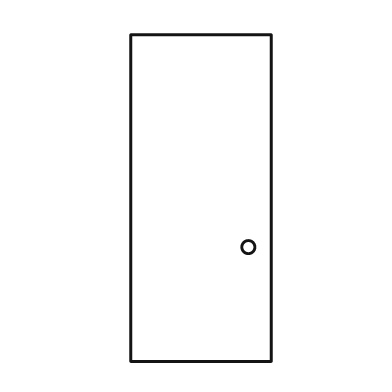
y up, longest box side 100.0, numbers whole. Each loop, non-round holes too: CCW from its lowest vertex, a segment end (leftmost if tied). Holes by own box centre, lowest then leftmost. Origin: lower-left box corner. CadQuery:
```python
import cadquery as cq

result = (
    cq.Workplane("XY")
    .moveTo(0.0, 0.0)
    .lineTo(43.0, 0.0)
    .lineTo(43.0, 100.0)
    .lineTo(0.0, 100.0)
    .close()
    .moveTo(36.0, 35.0)
    .circle(2.0)
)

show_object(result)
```